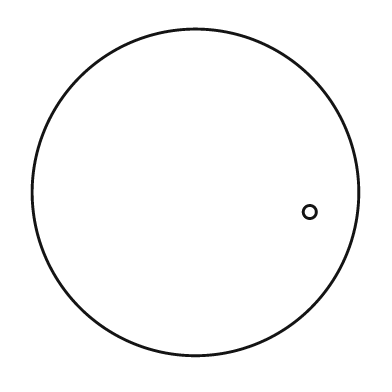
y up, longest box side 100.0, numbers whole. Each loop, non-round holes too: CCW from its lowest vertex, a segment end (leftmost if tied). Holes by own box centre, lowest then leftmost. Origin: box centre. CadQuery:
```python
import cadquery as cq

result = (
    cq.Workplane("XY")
    .moveTo(0.0, 0.0)
    .circle(50.0)
    .moveTo(35.0, -6.0)
    .circle(2.0)
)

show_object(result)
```